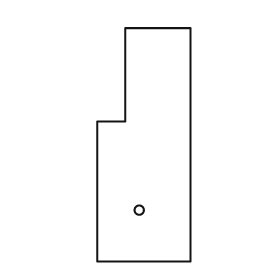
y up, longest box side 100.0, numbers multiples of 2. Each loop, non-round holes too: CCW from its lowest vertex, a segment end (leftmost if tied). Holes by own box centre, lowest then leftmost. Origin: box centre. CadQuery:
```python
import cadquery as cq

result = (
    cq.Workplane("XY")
    .moveTo(-20.0, -50.0)
    .lineTo(20.0, -50.0)
    .lineTo(20.0, 50.0)
    .lineTo(-8.0, 50.0)
    .lineTo(-8.0, 10.0)
    .lineTo(-20.0, 10.0)
    .close()
    .moveTo(-2.0, -28.0)
    .circle(2.0)
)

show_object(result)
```